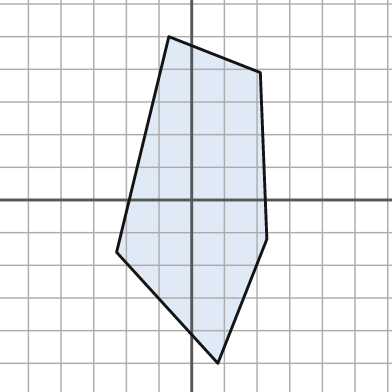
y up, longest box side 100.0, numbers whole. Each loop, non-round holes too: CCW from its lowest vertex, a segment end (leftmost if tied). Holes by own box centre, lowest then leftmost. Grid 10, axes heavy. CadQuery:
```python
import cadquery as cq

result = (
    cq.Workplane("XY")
    .moveTo(8.0, -50.0)
    .lineTo(23.0, -12.0)
    .lineTo(21.0, 39.0)
    .lineTo(-7.0, 50.0)
    .lineTo(-23.0, -16.0)
    .close()
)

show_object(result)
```